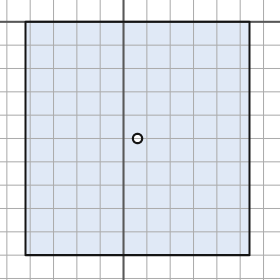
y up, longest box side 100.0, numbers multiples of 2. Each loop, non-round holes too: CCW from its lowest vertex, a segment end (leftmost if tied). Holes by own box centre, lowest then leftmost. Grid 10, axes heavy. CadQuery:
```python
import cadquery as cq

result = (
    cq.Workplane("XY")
    .moveTo(-42.0, -100.0)
    .lineTo(54.0, -100.0)
    .lineTo(54.0, 0.0)
    .lineTo(-42.0, 0.0)
    .close()
    .moveTo(6.0, -50.0)
    .circle(2.0)
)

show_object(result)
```